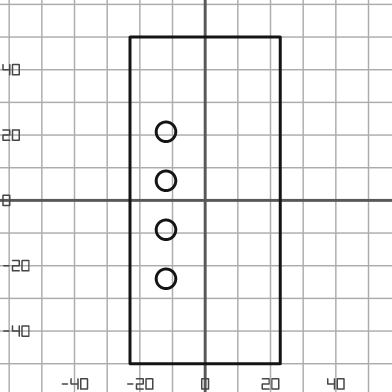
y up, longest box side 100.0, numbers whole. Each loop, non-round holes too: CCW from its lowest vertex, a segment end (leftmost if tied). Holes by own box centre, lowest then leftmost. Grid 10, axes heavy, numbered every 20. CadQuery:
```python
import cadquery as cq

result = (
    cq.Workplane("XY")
    .moveTo(-23.0, -50.0)
    .lineTo(23.0, -50.0)
    .lineTo(23.0, 50.0)
    .lineTo(-23.0, 50.0)
    .close()
    .moveTo(-12.0, -24.0)
    .circle(3.0)
    .moveTo(-12.0, -9.0)
    .circle(3.0)
    .moveTo(-12.0, 6.0)
    .circle(3.0)
    .moveTo(-12.0, 21.0)
    .circle(3.0)
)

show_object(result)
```